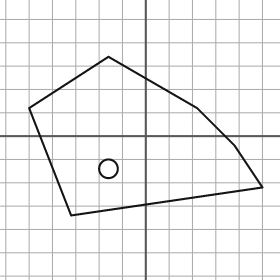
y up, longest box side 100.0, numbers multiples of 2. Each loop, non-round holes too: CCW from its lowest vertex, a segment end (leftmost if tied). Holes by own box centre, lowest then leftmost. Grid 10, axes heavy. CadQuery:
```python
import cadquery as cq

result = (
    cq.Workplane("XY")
    .moveTo(-32.0, -34.0)
    .lineTo(50.0, -22.0)
    .lineTo(38.0, -4.0)
    .lineTo(22.0, 12.0)
    .lineTo(-16.0, 34.0)
    .lineTo(-50.0, 12.0)
    .close()
    .moveTo(-16.0, -14.0)
    .circle(4.0)
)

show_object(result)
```